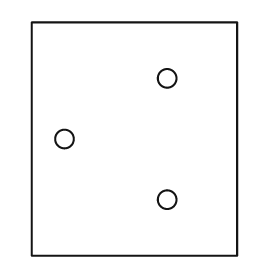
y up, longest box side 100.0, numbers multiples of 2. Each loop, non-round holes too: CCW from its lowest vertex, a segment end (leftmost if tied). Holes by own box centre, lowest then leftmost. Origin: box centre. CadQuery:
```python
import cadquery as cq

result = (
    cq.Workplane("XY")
    .moveTo(-44.0, -50.0)
    .lineTo(44.0, -50.0)
    .lineTo(44.0, 50.0)
    .lineTo(-44.0, 50.0)
    .close()
    .moveTo(14.0, -26.0)
    .circle(4.0)
    .moveTo(-30.0, 0.0)
    .circle(4.0)
    .moveTo(14.0, 26.0)
    .circle(4.0)
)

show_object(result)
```